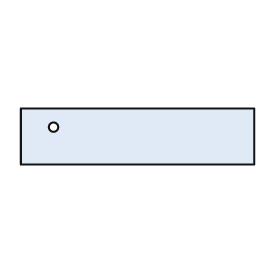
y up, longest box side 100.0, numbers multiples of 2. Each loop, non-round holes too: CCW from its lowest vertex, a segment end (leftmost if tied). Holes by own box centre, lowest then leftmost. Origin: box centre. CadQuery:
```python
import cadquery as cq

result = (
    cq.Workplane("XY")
    .moveTo(-50.0, -12.0)
    .lineTo(50.0, -12.0)
    .lineTo(50.0, 12.0)
    .lineTo(-50.0, 12.0)
    .close()
    .moveTo(-36.0, 4.0)
    .circle(2.0)
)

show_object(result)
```